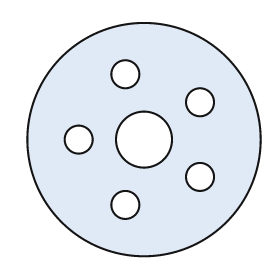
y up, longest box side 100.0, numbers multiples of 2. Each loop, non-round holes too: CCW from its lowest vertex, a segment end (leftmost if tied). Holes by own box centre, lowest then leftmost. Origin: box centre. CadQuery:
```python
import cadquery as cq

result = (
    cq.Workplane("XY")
    .moveTo(0.0, 0.0)
    .circle(50.0)
    .moveTo(-8.0, -28.0)
    .circle(6.0)
    .moveTo(24.0, -16.0)
    .circle(6.0)
    .moveTo(-28.0, 0.0)
    .circle(6.0)
    .moveTo(0.0, 0.0)
    .circle(12.0)
    .moveTo(24.0, 16.0)
    .circle(6.0)
    .moveTo(-8.0, 28.0)
    .circle(6.0)
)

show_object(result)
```